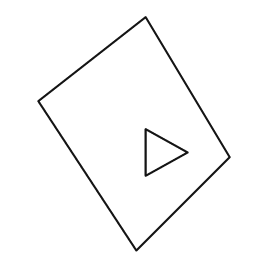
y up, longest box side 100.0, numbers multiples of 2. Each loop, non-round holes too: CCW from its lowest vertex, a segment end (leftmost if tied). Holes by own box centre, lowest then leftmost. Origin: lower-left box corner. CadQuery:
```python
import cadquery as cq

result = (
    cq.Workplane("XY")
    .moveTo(42.0, 0.0)
    .lineTo(82.0, 40.0)
    .lineTo(46.0, 100.0)
    .lineTo(0.0, 64.0)
    .close()
    .moveTo(46.0, 32.0)
    .lineTo(64.0, 42.0)
    .lineTo(46.0, 52.0)
    .close()
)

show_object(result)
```